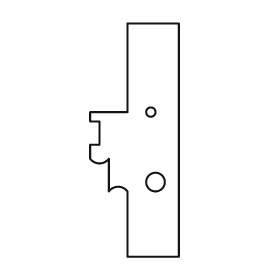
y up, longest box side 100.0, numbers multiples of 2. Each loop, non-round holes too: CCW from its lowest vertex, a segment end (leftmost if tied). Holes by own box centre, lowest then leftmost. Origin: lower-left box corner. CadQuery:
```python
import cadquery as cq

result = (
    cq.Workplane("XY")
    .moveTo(16.0, 0.0)
    .lineTo(38.0, 0.0)
    .lineTo(38.0, 100.0)
    .lineTo(16.0, 100.0)
    .lineTo(16.0, 62.0)
    .lineTo(0.0, 62.0)
    .lineTo(0.0, 58.0)
    .lineTo(4.0, 58.0)
    .lineTo(4.0, 48.0)
    .lineTo(0.0, 48.0)
    .lineTo(0.0, 42.0)
    .threePointArc((4.0, 40.0), (8.0, 42.0))
    .lineTo(8.0, 28.0)
    .threePointArc((12.0, 30.0), (16.0, 28.0))
    .close()
    .moveTo(28.0, 32.0)
    .circle(4.0)
    .moveTo(26.0, 62.0)
    .circle(2.0)
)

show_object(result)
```